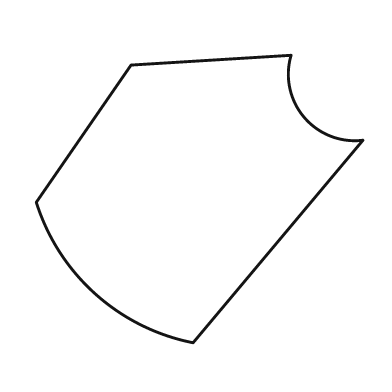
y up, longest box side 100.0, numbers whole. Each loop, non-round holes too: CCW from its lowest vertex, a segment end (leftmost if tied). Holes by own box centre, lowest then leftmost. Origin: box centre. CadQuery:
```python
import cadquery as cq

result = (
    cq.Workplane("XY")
    .moveTo(-2.0, -44.0)
    .lineTo(50.0, 18.0)
    .threePointArc((32.0, 25.0), (28.0, 44.0))
    .lineTo(-21.0, 41.0)
    .lineTo(-50.0, -1.0)
    .threePointArc((-32.0, -29.0), (-2.0, -44.0))
    .close()
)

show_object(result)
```